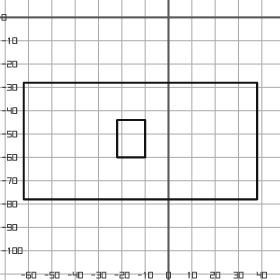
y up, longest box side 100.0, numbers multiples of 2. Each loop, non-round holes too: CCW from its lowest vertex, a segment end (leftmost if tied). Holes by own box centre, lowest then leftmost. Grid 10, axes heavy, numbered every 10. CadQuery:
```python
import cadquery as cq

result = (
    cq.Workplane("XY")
    .moveTo(-62.0, -78.0)
    .lineTo(38.0, -78.0)
    .lineTo(38.0, -28.0)
    .lineTo(-62.0, -28.0)
    .close()
    .moveTo(-22.0, -60.0)
    .lineTo(-10.0, -60.0)
    .lineTo(-10.0, -44.0)
    .lineTo(-22.0, -44.0)
    .close()
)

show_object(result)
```